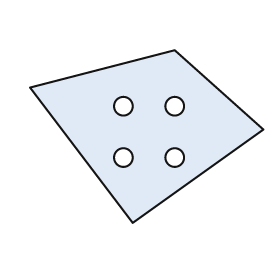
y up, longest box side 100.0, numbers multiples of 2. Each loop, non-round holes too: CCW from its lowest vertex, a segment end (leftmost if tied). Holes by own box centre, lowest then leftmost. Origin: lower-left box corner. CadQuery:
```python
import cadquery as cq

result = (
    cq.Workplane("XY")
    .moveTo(44.0, 0.0)
    .lineTo(100.0, 40.0)
    .lineTo(62.0, 74.0)
    .lineTo(0.0, 58.0)
    .close()
    .moveTo(40.0, 28.0)
    .circle(4.0)
    .moveTo(62.0, 28.0)
    .circle(4.0)
    .moveTo(40.0, 50.0)
    .circle(4.0)
    .moveTo(62.0, 50.0)
    .circle(4.0)
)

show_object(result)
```